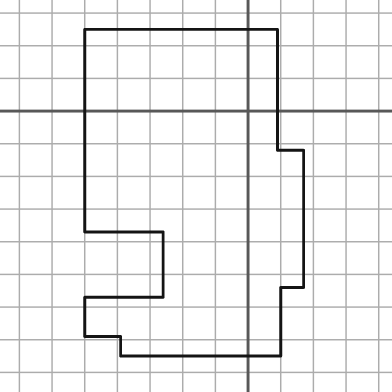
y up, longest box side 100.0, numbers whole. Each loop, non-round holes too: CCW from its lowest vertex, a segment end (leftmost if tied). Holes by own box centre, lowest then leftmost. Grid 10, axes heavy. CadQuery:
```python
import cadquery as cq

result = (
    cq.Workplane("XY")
    .moveTo(-39.0, -75.0)
    .lineTo(10.0, -75.0)
    .lineTo(10.0, -54.0)
    .lineTo(17.0, -54.0)
    .lineTo(17.0, -12.0)
    .lineTo(9.0, -12.0)
    .lineTo(9.0, 25.0)
    .lineTo(-50.0, 25.0)
    .lineTo(-50.0, -37.0)
    .lineTo(-26.0, -37.0)
    .lineTo(-26.0, -57.0)
    .lineTo(-50.0, -57.0)
    .lineTo(-50.0, -69.0)
    .lineTo(-39.0, -69.0)
    .close()
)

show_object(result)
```